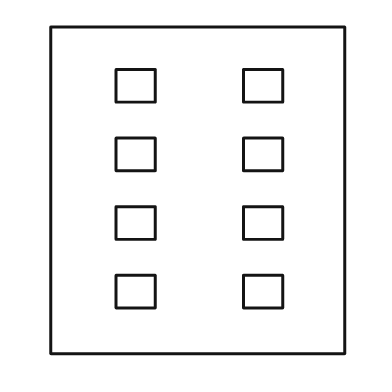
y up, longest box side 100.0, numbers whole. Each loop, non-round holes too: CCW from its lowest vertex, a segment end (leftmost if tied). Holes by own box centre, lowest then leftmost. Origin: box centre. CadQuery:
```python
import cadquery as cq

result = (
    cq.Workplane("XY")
    .moveTo(-45.0, -50.0)
    .lineTo(45.0, -50.0)
    .lineTo(45.0, 50.0)
    .lineTo(-45.0, 50.0)
    .close()
    .moveTo(-25.0, -36.0)
    .lineTo(-13.0, -36.0)
    .lineTo(-13.0, -26.0)
    .lineTo(-25.0, -26.0)
    .close()
    .moveTo(14.0, -36.0)
    .lineTo(26.0, -36.0)
    .lineTo(26.0, -26.0)
    .lineTo(14.0, -26.0)
    .close()
    .moveTo(-25.0, -15.0)
    .lineTo(-13.0, -15.0)
    .lineTo(-13.0, -5.0)
    .lineTo(-25.0, -5.0)
    .close()
    .moveTo(14.0, -15.0)
    .lineTo(26.0, -15.0)
    .lineTo(26.0, -5.0)
    .lineTo(14.0, -5.0)
    .close()
    .moveTo(-25.0, 6.0)
    .lineTo(-13.0, 6.0)
    .lineTo(-13.0, 16.0)
    .lineTo(-25.0, 16.0)
    .close()
    .moveTo(14.0, 6.0)
    .lineTo(26.0, 6.0)
    .lineTo(26.0, 16.0)
    .lineTo(14.0, 16.0)
    .close()
    .moveTo(-25.0, 27.0)
    .lineTo(-13.0, 27.0)
    .lineTo(-13.0, 37.0)
    .lineTo(-25.0, 37.0)
    .close()
    .moveTo(14.0, 27.0)
    .lineTo(26.0, 27.0)
    .lineTo(26.0, 37.0)
    .lineTo(14.0, 37.0)
    .close()
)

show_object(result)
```